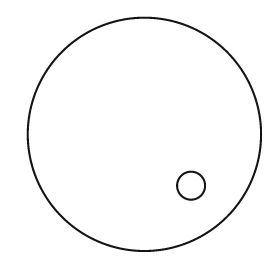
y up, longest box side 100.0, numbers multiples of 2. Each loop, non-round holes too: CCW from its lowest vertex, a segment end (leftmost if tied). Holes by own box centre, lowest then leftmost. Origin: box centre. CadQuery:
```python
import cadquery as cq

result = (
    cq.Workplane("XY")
    .moveTo(0.0, 0.0)
    .circle(50.0)
    .moveTo(20.0, -22.0)
    .circle(6.0)
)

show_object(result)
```